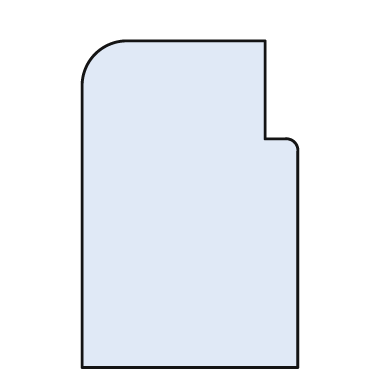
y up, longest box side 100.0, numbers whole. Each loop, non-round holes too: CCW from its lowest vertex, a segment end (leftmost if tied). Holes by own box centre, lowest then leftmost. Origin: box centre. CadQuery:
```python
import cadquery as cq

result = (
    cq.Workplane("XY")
    .moveTo(-33.0, -50.0)
    .lineTo(33.0, -50.0)
    .lineTo(33.0, 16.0)
    .threePointArc((32.0, 19.0), (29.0, 20.0))
    .lineTo(23.0, 20.0)
    .lineTo(23.0, 50.0)
    .lineTo(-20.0, 50.0)
    .threePointArc((-29.0, 46.0), (-33.0, 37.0))
    .close()
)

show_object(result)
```